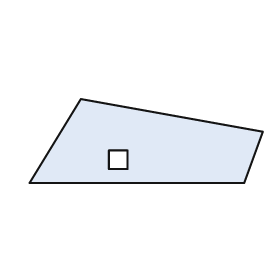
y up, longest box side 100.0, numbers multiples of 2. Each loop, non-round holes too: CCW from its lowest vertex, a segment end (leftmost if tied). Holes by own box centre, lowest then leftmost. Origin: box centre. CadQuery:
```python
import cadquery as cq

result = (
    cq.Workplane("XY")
    .moveTo(-50.0, -18.0)
    .lineTo(42.0, -18.0)
    .lineTo(50.0, 4.0)
    .lineTo(-28.0, 18.0)
    .close()
    .moveTo(-16.0, -12.0)
    .lineTo(-8.0, -12.0)
    .lineTo(-8.0, -4.0)
    .lineTo(-16.0, -4.0)
    .close()
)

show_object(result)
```